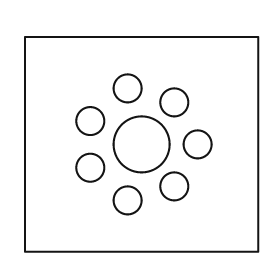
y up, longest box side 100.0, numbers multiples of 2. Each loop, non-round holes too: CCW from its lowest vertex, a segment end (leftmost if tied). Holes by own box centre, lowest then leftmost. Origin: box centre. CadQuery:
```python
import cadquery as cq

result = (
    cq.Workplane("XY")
    .moveTo(-50.0, -46.0)
    .lineTo(50.0, -46.0)
    .lineTo(50.0, 46.0)
    .lineTo(-50.0, 46.0)
    .close()
    .moveTo(-6.0, -24.0)
    .circle(6.0)
    .moveTo(14.0, -18.0)
    .circle(6.0)
    .moveTo(-22.0, -10.0)
    .circle(6.0)
    .moveTo(0.0, 0.0)
    .circle(12.0)
    .moveTo(24.0, 0.0)
    .circle(6.0)
    .moveTo(-22.0, 10.0)
    .circle(6.0)
    .moveTo(14.0, 18.0)
    .circle(6.0)
    .moveTo(-6.0, 24.0)
    .circle(6.0)
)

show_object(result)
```